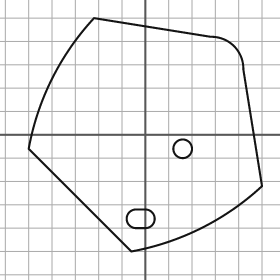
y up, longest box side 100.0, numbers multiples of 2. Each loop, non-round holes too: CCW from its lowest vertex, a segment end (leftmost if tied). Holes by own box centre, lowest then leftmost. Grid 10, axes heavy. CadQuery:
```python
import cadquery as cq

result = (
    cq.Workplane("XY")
    .moveTo(-6.0, -50.0)
    .threePointArc((24.0, -40.0), (50.0, -22.0))
    .lineTo(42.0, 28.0)
    .threePointArc((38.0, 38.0), (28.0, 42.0))
    .lineTo(-22.0, 50.0)
    .threePointArc((-40.0, 24.0), (-50.0, -6.0))
    .close()
    .moveTo(-4.0, -40.0)
    .lineTo(0.0, -40.0)
    .threePointArc((4.0, -36.0), (0.0, -32.0))
    .lineTo(-4.0, -32.0)
    .threePointArc((-8.0, -36.0), (-4.0, -40.0))
    .close()
    .moveTo(16.0, -6.0)
    .circle(4.0)
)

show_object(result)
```